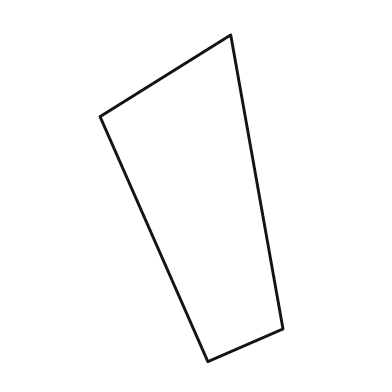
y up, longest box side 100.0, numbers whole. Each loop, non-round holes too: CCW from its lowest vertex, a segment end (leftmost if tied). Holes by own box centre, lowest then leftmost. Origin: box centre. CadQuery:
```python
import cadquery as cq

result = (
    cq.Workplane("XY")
    .moveTo(5.0, -50.0)
    .lineTo(28.0, -40.0)
    .lineTo(12.0, 50.0)
    .lineTo(-28.0, 25.0)
    .close()
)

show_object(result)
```